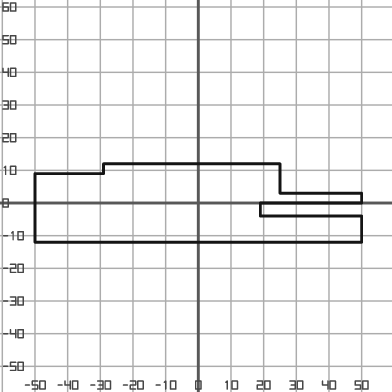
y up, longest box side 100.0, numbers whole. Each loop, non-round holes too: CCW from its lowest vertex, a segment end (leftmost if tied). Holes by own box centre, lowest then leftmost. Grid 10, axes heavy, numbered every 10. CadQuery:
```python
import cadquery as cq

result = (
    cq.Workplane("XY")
    .moveTo(-50.0, -12.0)
    .lineTo(50.0, -12.0)
    .lineTo(50.0, -4.0)
    .lineTo(19.0, -4.0)
    .lineTo(19.0, 0.0)
    .lineTo(50.0, 0.0)
    .lineTo(50.0, 3.0)
    .lineTo(25.0, 3.0)
    .lineTo(25.0, 12.0)
    .lineTo(-29.0, 12.0)
    .lineTo(-29.0, 9.0)
    .lineTo(-50.0, 9.0)
    .close()
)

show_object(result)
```